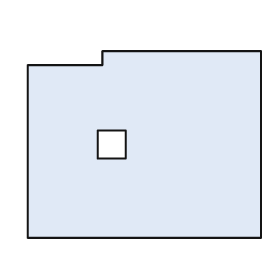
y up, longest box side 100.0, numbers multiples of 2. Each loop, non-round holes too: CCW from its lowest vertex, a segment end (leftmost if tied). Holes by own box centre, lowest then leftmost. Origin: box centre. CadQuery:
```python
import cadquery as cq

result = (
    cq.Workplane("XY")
    .moveTo(-50.0, -40.0)
    .lineTo(50.0, -40.0)
    .lineTo(50.0, 40.0)
    .lineTo(-18.0, 40.0)
    .lineTo(-18.0, 34.0)
    .lineTo(-50.0, 34.0)
    .close()
    .moveTo(-20.0, -6.0)
    .lineTo(-8.0, -6.0)
    .lineTo(-8.0, 6.0)
    .lineTo(-20.0, 6.0)
    .close()
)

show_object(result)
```